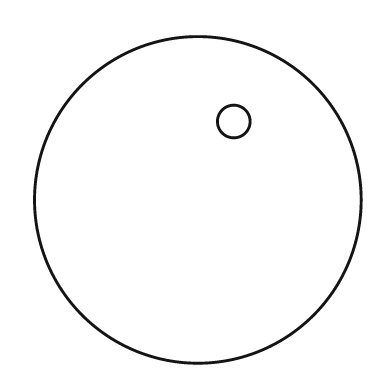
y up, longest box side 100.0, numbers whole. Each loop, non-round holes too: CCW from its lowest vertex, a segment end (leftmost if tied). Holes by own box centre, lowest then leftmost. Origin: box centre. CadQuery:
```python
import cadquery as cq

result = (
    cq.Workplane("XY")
    .moveTo(0.0, 0.0)
    .circle(50.0)
    .moveTo(11.0, 24.0)
    .circle(5.0)
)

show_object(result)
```